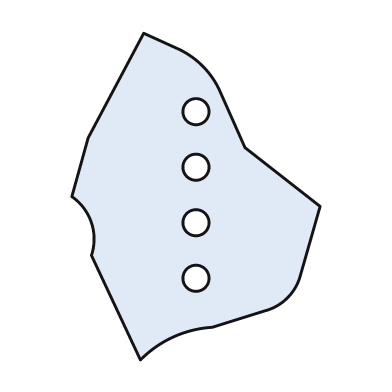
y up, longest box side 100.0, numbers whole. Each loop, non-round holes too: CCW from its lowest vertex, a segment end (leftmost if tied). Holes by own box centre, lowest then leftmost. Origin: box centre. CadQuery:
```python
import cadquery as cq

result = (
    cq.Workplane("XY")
    .moveTo(-17.0, -50.0)
    .threePointArc((-7.0, -43.0), (5.0, -40.0))
    .lineTo(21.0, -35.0)
    .threePointArc((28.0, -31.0), (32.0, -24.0))
    .lineTo(38.0, -3.0)
    .lineTo(15.0, 15.0)
    .lineTo(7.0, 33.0)
    .threePointArc((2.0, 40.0), (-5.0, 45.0))
    .lineTo(-16.0, 50.0)
    .lineTo(-33.0, 18.0)
    .lineTo(-38.0, 0.0)
    .threePointArc((-32.0, -8.0), (-32.0, -18.0))
    .close()
    .moveTo(0.0, -25.0)
    .circle(4.0)
    .moveTo(0.0, -8.0)
    .circle(4.0)
    .moveTo(0.0, 9.0)
    .circle(4.0)
    .moveTo(0.0, 26.0)
    .circle(4.0)
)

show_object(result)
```